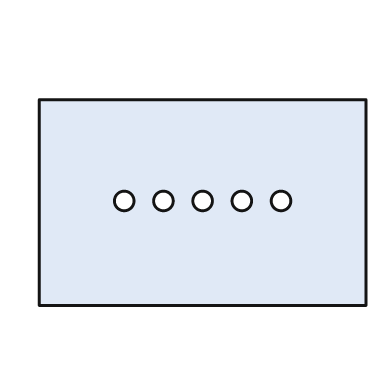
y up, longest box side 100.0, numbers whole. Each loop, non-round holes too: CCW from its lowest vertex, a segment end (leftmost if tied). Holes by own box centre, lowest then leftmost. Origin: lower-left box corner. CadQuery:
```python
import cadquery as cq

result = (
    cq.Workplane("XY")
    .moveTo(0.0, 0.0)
    .lineTo(100.0, 0.0)
    .lineTo(100.0, 63.0)
    .lineTo(0.0, 63.0)
    .close()
    .moveTo(26.0, 32.0)
    .circle(3.0)
    .moveTo(38.0, 32.0)
    .circle(3.0)
    .moveTo(50.0, 32.0)
    .circle(3.0)
    .moveTo(62.0, 32.0)
    .circle(3.0)
    .moveTo(74.0, 32.0)
    .circle(3.0)
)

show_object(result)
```